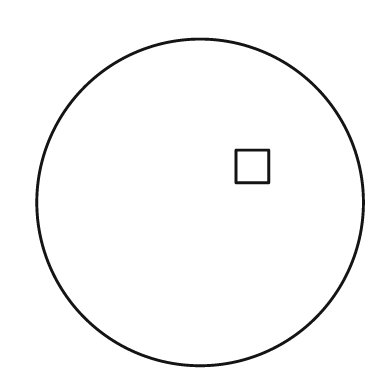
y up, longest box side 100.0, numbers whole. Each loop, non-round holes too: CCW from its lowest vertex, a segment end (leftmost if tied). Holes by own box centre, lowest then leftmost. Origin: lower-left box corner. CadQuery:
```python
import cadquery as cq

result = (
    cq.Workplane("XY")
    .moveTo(50.0, 50.0)
    .circle(50.0)
    .moveTo(61.0, 56.0)
    .lineTo(71.0, 56.0)
    .lineTo(71.0, 66.0)
    .lineTo(61.0, 66.0)
    .close()
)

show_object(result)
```